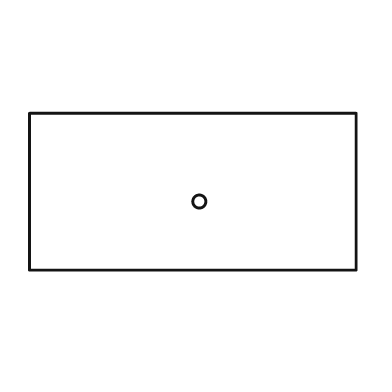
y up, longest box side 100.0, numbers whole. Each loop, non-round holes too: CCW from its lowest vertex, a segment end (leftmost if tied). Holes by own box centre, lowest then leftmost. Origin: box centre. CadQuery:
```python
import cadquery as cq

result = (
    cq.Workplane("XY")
    .moveTo(-50.0, -24.0)
    .lineTo(50.0, -24.0)
    .lineTo(50.0, 24.0)
    .lineTo(-50.0, 24.0)
    .close()
    .moveTo(2.0, -3.0)
    .circle(2.0)
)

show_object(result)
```